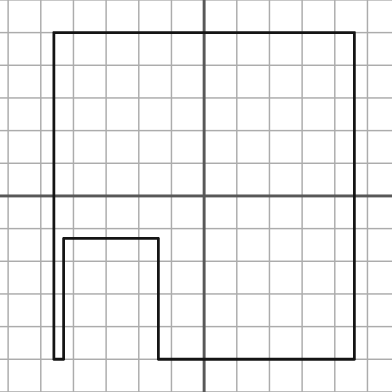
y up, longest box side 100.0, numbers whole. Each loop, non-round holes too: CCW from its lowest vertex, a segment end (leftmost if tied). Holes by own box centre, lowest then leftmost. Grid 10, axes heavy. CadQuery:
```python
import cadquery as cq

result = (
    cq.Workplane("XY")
    .moveTo(-46.0, -50.0)
    .lineTo(-43.0, -50.0)
    .lineTo(-43.0, -13.0)
    .lineTo(-14.0, -13.0)
    .lineTo(-14.0, -50.0)
    .lineTo(46.0, -50.0)
    .lineTo(46.0, 50.0)
    .lineTo(-46.0, 50.0)
    .close()
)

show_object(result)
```